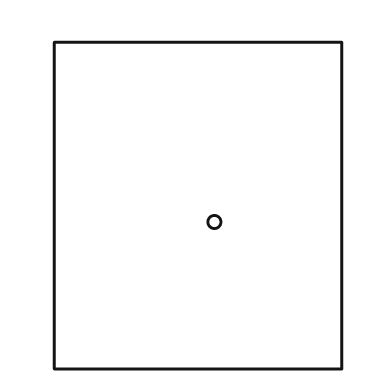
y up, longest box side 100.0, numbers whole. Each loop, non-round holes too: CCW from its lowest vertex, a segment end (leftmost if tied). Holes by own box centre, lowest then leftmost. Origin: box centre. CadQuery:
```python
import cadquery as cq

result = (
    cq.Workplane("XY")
    .moveTo(-44.0, -50.0)
    .lineTo(44.0, -50.0)
    .lineTo(44.0, 50.0)
    .lineTo(-44.0, 50.0)
    .close()
    .moveTo(5.0, -5.0)
    .circle(2.0)
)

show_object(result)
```